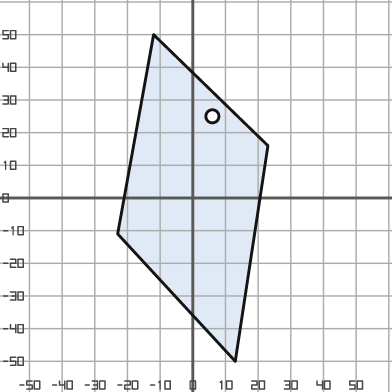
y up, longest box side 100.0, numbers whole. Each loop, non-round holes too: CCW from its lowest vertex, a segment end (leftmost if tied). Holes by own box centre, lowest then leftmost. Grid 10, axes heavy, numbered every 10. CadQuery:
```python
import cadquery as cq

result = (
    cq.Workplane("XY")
    .moveTo(13.0, -50.0)
    .lineTo(23.0, 16.0)
    .lineTo(-12.0, 50.0)
    .lineTo(-23.0, -11.0)
    .close()
    .moveTo(6.0, 25.0)
    .circle(2.0)
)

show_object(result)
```